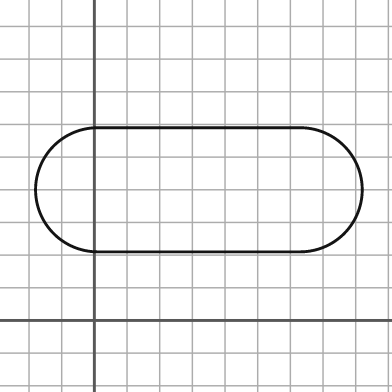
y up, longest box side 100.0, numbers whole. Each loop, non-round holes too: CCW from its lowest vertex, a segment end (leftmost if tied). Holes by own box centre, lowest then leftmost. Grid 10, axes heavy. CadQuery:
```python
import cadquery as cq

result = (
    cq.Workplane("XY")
    .moveTo(1.0, 21.0)
    .lineTo(63.0, 21.0)
    .threePointArc((82.0, 40.0), (63.0, 59.0))
    .lineTo(1.0, 59.0)
    .threePointArc((-18.0, 40.0), (1.0, 21.0))
    .close()
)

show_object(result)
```